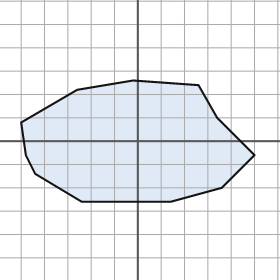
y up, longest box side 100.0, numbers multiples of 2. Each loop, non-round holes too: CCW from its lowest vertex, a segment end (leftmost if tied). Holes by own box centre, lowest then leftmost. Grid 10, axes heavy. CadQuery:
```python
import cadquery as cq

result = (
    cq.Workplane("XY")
    .moveTo(-24.0, -26.0)
    .lineTo(14.0, -26.0)
    .lineTo(36.0, -20.0)
    .lineTo(50.0, -6.0)
    .lineTo(34.0, 10.0)
    .lineTo(26.0, 24.0)
    .lineTo(-2.0, 26.0)
    .lineTo(-26.0, 22.0)
    .lineTo(-50.0, 8.0)
    .lineTo(-48.0, -6.0)
    .lineTo(-44.0, -14.0)
    .close()
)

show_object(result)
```